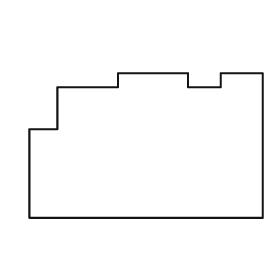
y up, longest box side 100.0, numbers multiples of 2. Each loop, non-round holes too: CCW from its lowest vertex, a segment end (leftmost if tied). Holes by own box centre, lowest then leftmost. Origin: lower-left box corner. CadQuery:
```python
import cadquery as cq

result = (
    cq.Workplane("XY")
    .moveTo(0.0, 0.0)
    .lineTo(100.0, 0.0)
    .lineTo(100.0, 62.0)
    .lineTo(82.0, 62.0)
    .lineTo(82.0, 56.0)
    .lineTo(68.0, 56.0)
    .lineTo(68.0, 62.0)
    .lineTo(38.0, 62.0)
    .lineTo(38.0, 56.0)
    .lineTo(12.0, 56.0)
    .lineTo(12.0, 38.0)
    .lineTo(0.0, 38.0)
    .close()
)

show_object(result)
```